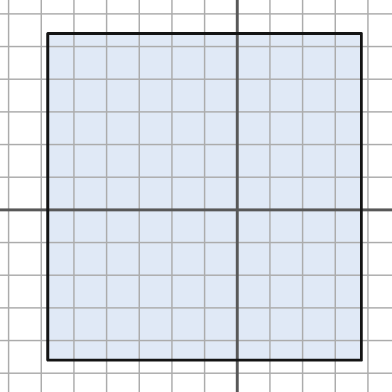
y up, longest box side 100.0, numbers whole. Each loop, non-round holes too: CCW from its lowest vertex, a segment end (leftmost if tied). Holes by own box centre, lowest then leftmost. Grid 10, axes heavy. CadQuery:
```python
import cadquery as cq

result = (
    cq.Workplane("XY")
    .moveTo(-58.0, -46.0)
    .lineTo(38.0, -46.0)
    .lineTo(38.0, 54.0)
    .lineTo(-58.0, 54.0)
    .close()
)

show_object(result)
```